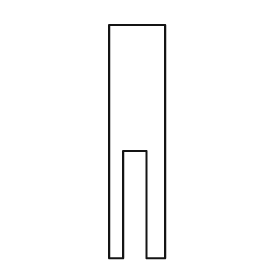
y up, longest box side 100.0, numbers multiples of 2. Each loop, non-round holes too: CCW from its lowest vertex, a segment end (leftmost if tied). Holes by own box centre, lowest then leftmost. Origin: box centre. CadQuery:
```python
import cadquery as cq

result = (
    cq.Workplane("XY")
    .moveTo(-12.0, -50.0)
    .lineTo(-6.0, -50.0)
    .lineTo(-6.0, -4.0)
    .lineTo(4.0, -4.0)
    .lineTo(4.0, -50.0)
    .lineTo(12.0, -50.0)
    .lineTo(12.0, 50.0)
    .lineTo(-12.0, 50.0)
    .close()
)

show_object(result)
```